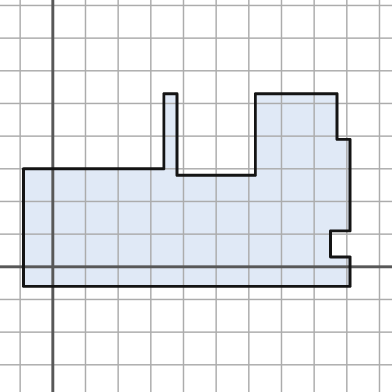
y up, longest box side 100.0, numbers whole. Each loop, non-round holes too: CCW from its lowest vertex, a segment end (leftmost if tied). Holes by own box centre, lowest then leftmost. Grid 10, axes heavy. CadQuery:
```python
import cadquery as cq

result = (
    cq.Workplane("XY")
    .moveTo(-9.0, -6.0)
    .lineTo(91.0, -6.0)
    .lineTo(91.0, 3.0)
    .lineTo(85.0, 3.0)
    .lineTo(85.0, 11.0)
    .lineTo(91.0, 11.0)
    .lineTo(91.0, 39.0)
    .lineTo(87.0, 39.0)
    .lineTo(87.0, 53.0)
    .lineTo(62.0, 53.0)
    .lineTo(62.0, 28.0)
    .lineTo(38.0, 28.0)
    .lineTo(38.0, 53.0)
    .lineTo(34.0, 53.0)
    .lineTo(34.0, 30.0)
    .lineTo(-9.0, 30.0)
    .close()
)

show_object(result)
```